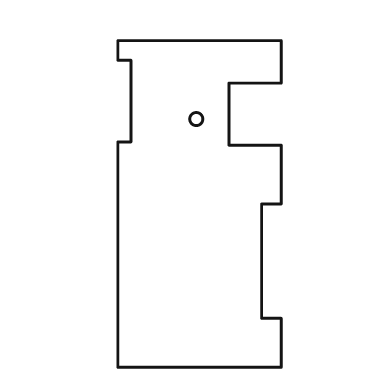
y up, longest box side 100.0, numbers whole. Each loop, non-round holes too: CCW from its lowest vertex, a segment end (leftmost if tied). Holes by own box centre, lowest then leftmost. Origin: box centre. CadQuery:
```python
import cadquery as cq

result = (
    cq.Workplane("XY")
    .moveTo(-25.0, -50.0)
    .lineTo(25.0, -50.0)
    .lineTo(25.0, -35.0)
    .lineTo(19.0, -35.0)
    .lineTo(19.0, 0.0)
    .lineTo(25.0, 0.0)
    .lineTo(25.0, 18.0)
    .lineTo(9.0, 18.0)
    .lineTo(9.0, 37.0)
    .lineTo(25.0, 37.0)
    .lineTo(25.0, 50.0)
    .lineTo(-25.0, 50.0)
    .lineTo(-25.0, 44.0)
    .lineTo(-21.0, 44.0)
    .lineTo(-21.0, 19.0)
    .lineTo(-25.0, 19.0)
    .close()
    .moveTo(-1.0, 26.0)
    .circle(2.0)
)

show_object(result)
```